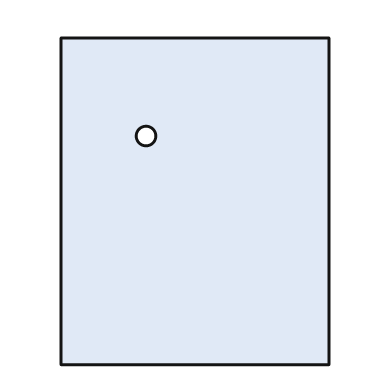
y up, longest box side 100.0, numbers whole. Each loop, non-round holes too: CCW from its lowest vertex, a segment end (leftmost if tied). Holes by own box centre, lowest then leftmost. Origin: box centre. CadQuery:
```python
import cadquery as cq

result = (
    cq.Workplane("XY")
    .moveTo(-41.0, -50.0)
    .lineTo(41.0, -50.0)
    .lineTo(41.0, 50.0)
    .lineTo(-41.0, 50.0)
    .close()
    .moveTo(-15.0, 20.0)
    .circle(3.0)
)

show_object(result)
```